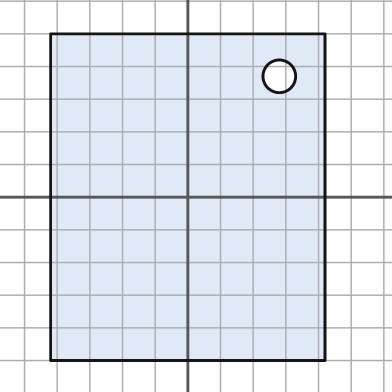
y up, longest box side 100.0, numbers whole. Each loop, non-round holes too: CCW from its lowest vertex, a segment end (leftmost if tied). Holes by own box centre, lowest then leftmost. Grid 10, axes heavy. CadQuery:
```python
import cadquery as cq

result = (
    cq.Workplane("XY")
    .moveTo(-42.0, -50.0)
    .lineTo(42.0, -50.0)
    .lineTo(42.0, 50.0)
    .lineTo(-42.0, 50.0)
    .close()
    .moveTo(28.0, 37.0)
    .circle(5.0)
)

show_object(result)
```